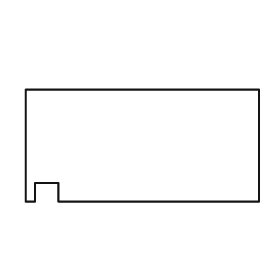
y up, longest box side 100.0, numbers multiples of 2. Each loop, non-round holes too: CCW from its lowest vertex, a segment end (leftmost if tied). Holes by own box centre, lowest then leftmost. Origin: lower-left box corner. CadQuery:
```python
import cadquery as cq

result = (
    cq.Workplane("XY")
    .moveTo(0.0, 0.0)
    .lineTo(4.0, 0.0)
    .lineTo(4.0, 8.0)
    .lineTo(14.0, 8.0)
    .lineTo(14.0, 0.0)
    .lineTo(100.0, 0.0)
    .lineTo(100.0, 48.0)
    .lineTo(0.0, 48.0)
    .close()
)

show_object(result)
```